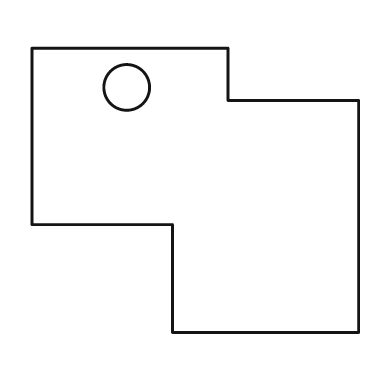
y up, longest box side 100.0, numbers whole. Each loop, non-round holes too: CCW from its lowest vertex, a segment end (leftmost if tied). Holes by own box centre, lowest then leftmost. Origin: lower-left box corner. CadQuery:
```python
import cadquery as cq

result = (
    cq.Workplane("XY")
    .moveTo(43.0, 0.0)
    .lineTo(100.0, 0.0)
    .lineTo(100.0, 71.0)
    .lineTo(60.0, 71.0)
    .lineTo(60.0, 87.0)
    .lineTo(0.0, 87.0)
    .lineTo(0.0, 33.0)
    .lineTo(43.0, 33.0)
    .close()
    .moveTo(29.0, 75.0)
    .circle(7.0)
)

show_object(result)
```